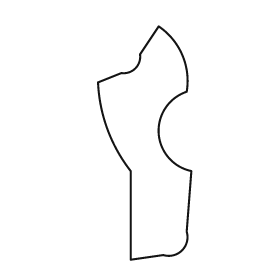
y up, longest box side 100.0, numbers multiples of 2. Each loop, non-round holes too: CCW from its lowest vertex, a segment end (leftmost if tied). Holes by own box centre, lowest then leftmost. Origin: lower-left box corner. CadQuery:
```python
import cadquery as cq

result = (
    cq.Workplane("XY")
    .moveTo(14.0, 0.0)
    .lineTo(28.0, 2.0)
    .threePointArc((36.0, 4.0), (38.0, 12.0))
    .lineTo(40.0, 38.0)
    .threePointArc((26.0, 54.0), (38.0, 72.0))
    .threePointArc((36.0, 88.0), (26.0, 100.0))
    .lineTo(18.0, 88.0)
    .threePointArc((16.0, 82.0), (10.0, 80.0))
    .lineTo(0.0, 76.0)
    .threePointArc((4.0, 56.0), (14.0, 38.0))
    .close()
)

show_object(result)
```